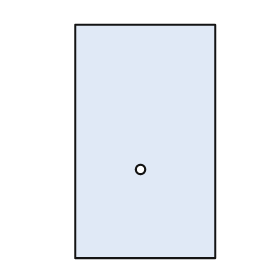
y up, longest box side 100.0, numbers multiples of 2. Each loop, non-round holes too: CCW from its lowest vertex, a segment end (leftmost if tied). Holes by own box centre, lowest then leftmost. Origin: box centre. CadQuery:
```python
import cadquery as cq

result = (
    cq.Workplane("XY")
    .moveTo(-30.0, -50.0)
    .lineTo(30.0, -50.0)
    .lineTo(30.0, 50.0)
    .lineTo(-30.0, 50.0)
    .close()
    .moveTo(-2.0, -12.0)
    .circle(2.0)
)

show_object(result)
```